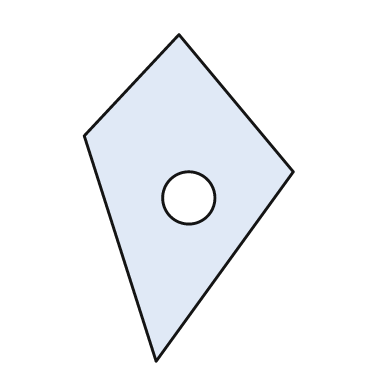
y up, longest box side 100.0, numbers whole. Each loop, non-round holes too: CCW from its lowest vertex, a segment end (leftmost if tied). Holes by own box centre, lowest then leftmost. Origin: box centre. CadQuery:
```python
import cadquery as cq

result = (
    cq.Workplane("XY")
    .moveTo(-10.0, -50.0)
    .lineTo(32.0, 8.0)
    .lineTo(-3.0, 50.0)
    .lineTo(-32.0, 19.0)
    .close()
    .moveTo(0.0, 0.0)
    .circle(8.0)
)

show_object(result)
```